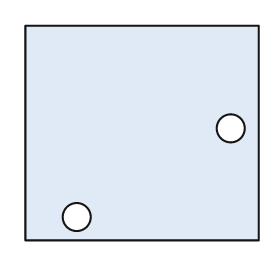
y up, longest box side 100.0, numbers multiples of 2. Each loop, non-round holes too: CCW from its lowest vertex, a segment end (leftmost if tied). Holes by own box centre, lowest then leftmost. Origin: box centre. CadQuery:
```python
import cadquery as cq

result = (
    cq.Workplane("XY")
    .moveTo(-50.0, -46.0)
    .lineTo(50.0, -46.0)
    .lineTo(50.0, 46.0)
    .lineTo(-50.0, 46.0)
    .close()
    .moveTo(-28.0, -36.0)
    .circle(6.0)
    .moveTo(38.0, 2.0)
    .circle(6.0)
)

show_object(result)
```